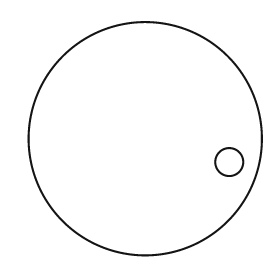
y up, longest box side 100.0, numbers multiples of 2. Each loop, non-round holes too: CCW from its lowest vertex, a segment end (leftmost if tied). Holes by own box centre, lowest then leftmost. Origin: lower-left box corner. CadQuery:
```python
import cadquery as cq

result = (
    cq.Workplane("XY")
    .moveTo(50.0, 50.0)
    .circle(50.0)
    .moveTo(86.0, 40.0)
    .circle(6.0)
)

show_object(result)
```